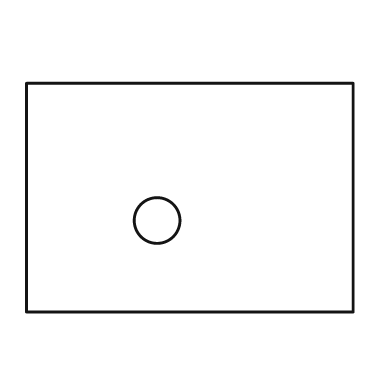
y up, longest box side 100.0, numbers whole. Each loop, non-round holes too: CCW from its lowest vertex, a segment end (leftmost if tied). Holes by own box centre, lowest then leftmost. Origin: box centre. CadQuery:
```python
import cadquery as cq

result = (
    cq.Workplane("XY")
    .moveTo(-50.0, -35.0)
    .lineTo(50.0, -35.0)
    .lineTo(50.0, 35.0)
    .lineTo(-50.0, 35.0)
    .close()
    .moveTo(-10.0, -7.0)
    .circle(7.0)
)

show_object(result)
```